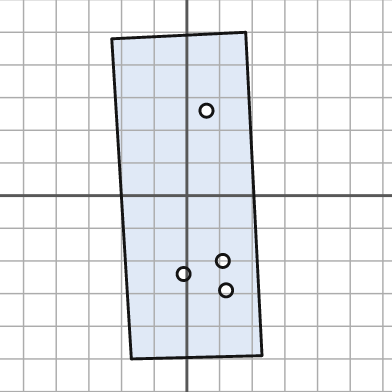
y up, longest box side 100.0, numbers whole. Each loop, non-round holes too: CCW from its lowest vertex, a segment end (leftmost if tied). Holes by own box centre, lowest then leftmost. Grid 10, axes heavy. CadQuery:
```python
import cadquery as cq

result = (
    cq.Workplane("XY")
    .moveTo(-17.0, -50.0)
    .lineTo(23.0, -49.0)
    .lineTo(18.0, 50.0)
    .lineTo(-23.0, 48.0)
    .close()
    .moveTo(12.0, -29.0)
    .circle(2.0)
    .moveTo(-1.0, -24.0)
    .circle(2.0)
    .moveTo(11.0, -20.0)
    .circle(2.0)
    .moveTo(6.0, 26.0)
    .circle(2.0)
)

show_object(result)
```